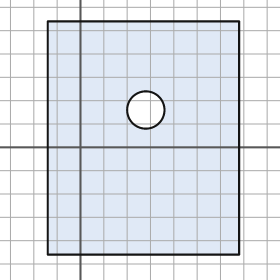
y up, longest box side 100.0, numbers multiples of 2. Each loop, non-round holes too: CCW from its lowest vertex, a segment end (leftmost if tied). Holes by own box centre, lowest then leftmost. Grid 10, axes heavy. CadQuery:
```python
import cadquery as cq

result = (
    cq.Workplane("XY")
    .moveTo(-14.0, -46.0)
    .lineTo(68.0, -46.0)
    .lineTo(68.0, 54.0)
    .lineTo(-14.0, 54.0)
    .close()
    .moveTo(28.0, 16.0)
    .circle(8.0)
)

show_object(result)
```